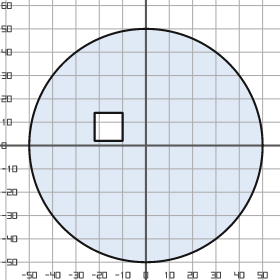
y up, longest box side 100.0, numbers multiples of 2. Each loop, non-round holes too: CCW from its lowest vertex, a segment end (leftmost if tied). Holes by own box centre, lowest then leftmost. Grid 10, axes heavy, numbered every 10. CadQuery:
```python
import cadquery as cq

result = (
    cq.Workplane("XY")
    .moveTo(0.0, 0.0)
    .circle(50.0)
    .moveTo(-22.0, 2.0)
    .lineTo(-10.0, 2.0)
    .lineTo(-10.0, 14.0)
    .lineTo(-22.0, 14.0)
    .close()
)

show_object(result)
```